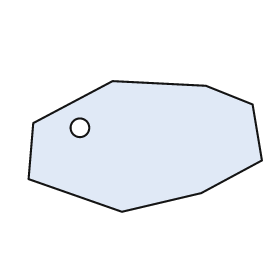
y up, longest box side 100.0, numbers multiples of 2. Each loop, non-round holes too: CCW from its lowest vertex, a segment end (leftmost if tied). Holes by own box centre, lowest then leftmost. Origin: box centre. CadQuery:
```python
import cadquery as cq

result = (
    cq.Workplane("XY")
    .moveTo(-10.0, -28.0)
    .lineTo(24.0, -20.0)
    .lineTo(50.0, -6.0)
    .lineTo(46.0, 18.0)
    .lineTo(26.0, 26.0)
    .lineTo(-14.0, 28.0)
    .lineTo(-48.0, 10.0)
    .lineTo(-50.0, -14.0)
    .close()
    .moveTo(-28.0, 8.0)
    .circle(4.0)
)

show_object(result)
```